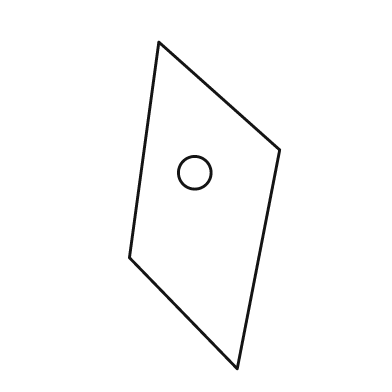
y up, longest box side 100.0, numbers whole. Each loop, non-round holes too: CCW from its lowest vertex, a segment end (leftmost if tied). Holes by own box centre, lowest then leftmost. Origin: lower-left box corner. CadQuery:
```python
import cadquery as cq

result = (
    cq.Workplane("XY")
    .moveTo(33.0, 0.0)
    .lineTo(46.0, 67.0)
    .lineTo(9.0, 100.0)
    .lineTo(0.0, 34.0)
    .close()
    .moveTo(20.0, 60.0)
    .circle(5.0)
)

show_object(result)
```